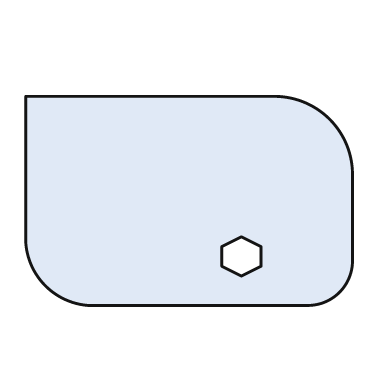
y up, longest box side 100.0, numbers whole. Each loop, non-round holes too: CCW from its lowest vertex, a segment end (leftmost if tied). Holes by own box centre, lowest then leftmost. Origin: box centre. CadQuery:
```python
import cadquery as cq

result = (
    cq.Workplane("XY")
    .moveTo(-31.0, -32.0)
    .lineTo(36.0, -32.0)
    .threePointArc((46.0, -28.0), (50.0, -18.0))
    .lineTo(50.0, 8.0)
    .threePointArc((43.0, 25.0), (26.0, 32.0))
    .lineTo(-50.0, 32.0)
    .lineTo(-50.0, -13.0)
    .threePointArc((-44.0, -26.0), (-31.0, -32.0))
    .close()
    .moveTo(16.0, -23.0)
    .lineTo(22.0, -20.0)
    .lineTo(22.0, -14.0)
    .lineTo(16.0, -11.0)
    .lineTo(10.0, -14.0)
    .lineTo(10.0, -20.0)
    .close()
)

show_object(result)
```